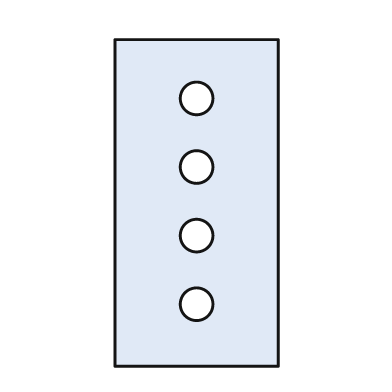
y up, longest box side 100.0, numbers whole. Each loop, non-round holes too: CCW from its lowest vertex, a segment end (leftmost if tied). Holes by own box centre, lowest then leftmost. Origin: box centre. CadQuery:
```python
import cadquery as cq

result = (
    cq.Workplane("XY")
    .moveTo(-25.0, -50.0)
    .lineTo(25.0, -50.0)
    .lineTo(25.0, 50.0)
    .lineTo(-25.0, 50.0)
    .close()
    .moveTo(0.0, -31.0)
    .circle(5.0)
    .moveTo(0.0, -10.0)
    .circle(5.0)
    .moveTo(0.0, 11.0)
    .circle(5.0)
    .moveTo(0.0, 32.0)
    .circle(5.0)
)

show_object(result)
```